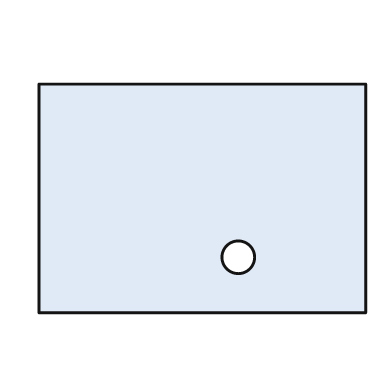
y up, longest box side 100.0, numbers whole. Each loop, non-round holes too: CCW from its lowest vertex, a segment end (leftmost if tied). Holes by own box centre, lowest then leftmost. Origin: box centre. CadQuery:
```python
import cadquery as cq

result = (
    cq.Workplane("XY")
    .moveTo(-50.0, -35.0)
    .lineTo(50.0, -35.0)
    .lineTo(50.0, 35.0)
    .lineTo(-50.0, 35.0)
    .close()
    .moveTo(11.0, -18.0)
    .circle(5.0)
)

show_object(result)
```